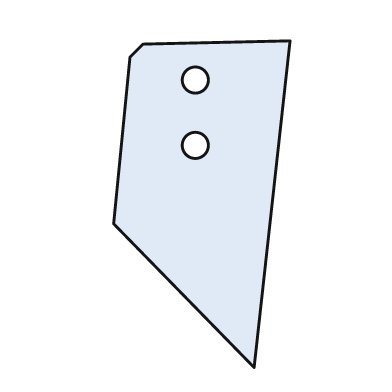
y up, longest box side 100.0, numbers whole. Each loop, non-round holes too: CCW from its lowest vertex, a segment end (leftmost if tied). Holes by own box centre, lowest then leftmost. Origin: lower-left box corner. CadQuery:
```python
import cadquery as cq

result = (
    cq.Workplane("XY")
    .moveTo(43.0, 0.0)
    .lineTo(54.0, 100.0)
    .lineTo(9.0, 99.0)
    .lineTo(5.0, 95.0)
    .lineTo(0.0, 44.0)
    .close()
    .moveTo(25.0, 68.0)
    .circle(4.0)
    .moveTo(25.0, 88.0)
    .circle(4.0)
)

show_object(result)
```